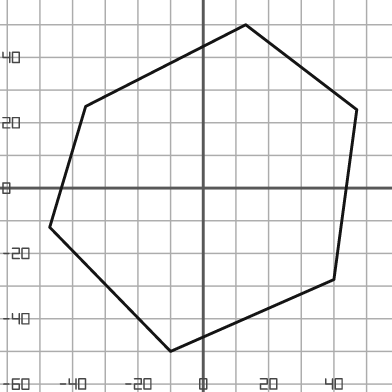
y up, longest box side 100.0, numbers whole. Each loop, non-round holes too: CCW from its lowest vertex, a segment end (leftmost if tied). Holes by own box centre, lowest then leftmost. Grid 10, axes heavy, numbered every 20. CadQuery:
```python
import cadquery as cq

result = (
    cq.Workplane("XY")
    .moveTo(-10.0, -50.0)
    .lineTo(40.0, -28.0)
    .lineTo(47.0, 24.0)
    .lineTo(13.0, 50.0)
    .lineTo(-36.0, 25.0)
    .lineTo(-47.0, -12.0)
    .close()
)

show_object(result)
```